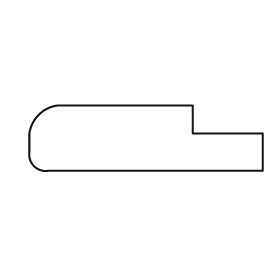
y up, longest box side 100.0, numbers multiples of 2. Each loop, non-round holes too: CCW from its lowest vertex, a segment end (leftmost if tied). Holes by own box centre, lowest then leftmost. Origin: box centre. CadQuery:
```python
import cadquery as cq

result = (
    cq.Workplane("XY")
    .moveTo(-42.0, -14.0)
    .lineTo(50.0, -14.0)
    .lineTo(50.0, 2.0)
    .lineTo(20.0, 2.0)
    .lineTo(20.0, 14.0)
    .lineTo(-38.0, 14.0)
    .threePointArc((-46.0, 10.0), (-50.0, 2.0))
    .lineTo(-50.0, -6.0)
    .threePointArc((-48.0, -12.0), (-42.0, -14.0))
    .close()
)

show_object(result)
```